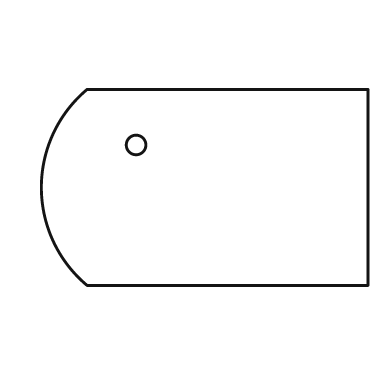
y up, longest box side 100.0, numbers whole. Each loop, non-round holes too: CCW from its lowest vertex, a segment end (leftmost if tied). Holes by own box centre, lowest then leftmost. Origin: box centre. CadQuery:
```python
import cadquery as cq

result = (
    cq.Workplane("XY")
    .moveTo(-36.0, -30.0)
    .lineTo(50.0, -30.0)
    .lineTo(50.0, 30.0)
    .lineTo(-36.0, 30.0)
    .threePointArc((-50.0, 0.0), (-36.0, -30.0))
    .close()
    .moveTo(-21.0, 13.0)
    .circle(3.0)
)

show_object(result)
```